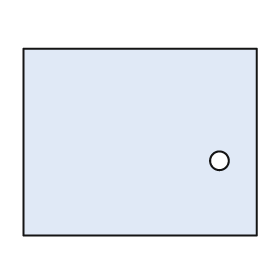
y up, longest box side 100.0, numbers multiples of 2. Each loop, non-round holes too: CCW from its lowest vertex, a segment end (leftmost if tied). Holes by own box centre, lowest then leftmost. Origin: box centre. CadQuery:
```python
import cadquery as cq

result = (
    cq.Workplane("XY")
    .moveTo(-50.0, -40.0)
    .lineTo(50.0, -40.0)
    .lineTo(50.0, 40.0)
    .lineTo(-50.0, 40.0)
    .close()
    .moveTo(34.0, -8.0)
    .circle(4.0)
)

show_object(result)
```